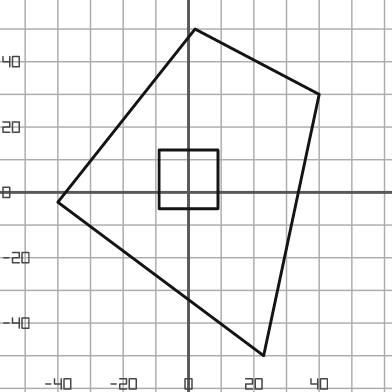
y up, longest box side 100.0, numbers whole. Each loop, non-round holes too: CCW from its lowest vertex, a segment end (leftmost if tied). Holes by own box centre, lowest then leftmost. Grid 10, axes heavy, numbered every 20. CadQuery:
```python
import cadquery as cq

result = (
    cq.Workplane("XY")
    .moveTo(23.0, -50.0)
    .lineTo(40.0, 30.0)
    .lineTo(2.0, 50.0)
    .lineTo(-40.0, -3.0)
    .close()
    .moveTo(-9.0, -5.0)
    .lineTo(9.0, -5.0)
    .lineTo(9.0, 13.0)
    .lineTo(-9.0, 13.0)
    .close()
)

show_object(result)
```